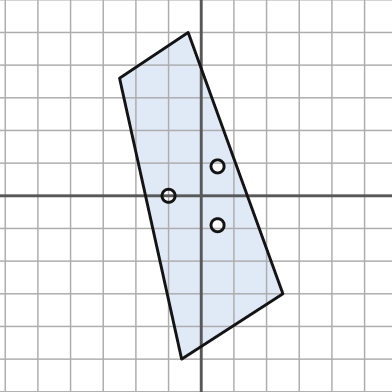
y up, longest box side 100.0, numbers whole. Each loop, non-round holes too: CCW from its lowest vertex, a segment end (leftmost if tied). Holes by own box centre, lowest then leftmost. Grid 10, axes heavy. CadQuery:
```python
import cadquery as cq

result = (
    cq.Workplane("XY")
    .moveTo(-6.0, -50.0)
    .lineTo(25.0, -30.0)
    .lineTo(-4.0, 50.0)
    .lineTo(-25.0, 36.0)
    .close()
    .moveTo(5.0, -9.0)
    .circle(2.0)
    .moveTo(-10.0, 0.0)
    .circle(2.0)
    .moveTo(5.0, 9.0)
    .circle(2.0)
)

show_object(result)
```